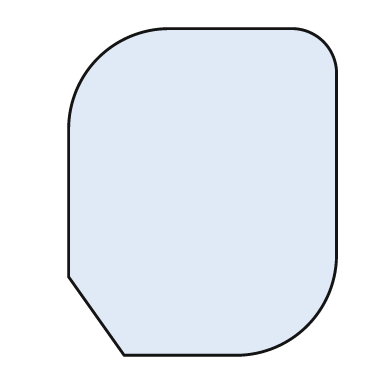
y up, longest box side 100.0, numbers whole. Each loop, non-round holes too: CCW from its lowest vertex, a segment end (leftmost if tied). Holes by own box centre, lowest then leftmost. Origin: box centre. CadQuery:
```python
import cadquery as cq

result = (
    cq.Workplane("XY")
    .moveTo(-24.0, -50.0)
    .lineTo(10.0, -50.0)
    .threePointArc((32.0, -41.0), (41.0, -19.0))
    .lineTo(41.0, 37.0)
    .threePointArc((37.0, 46.0), (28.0, 50.0))
    .lineTo(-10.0, 50.0)
    .threePointArc((-32.0, 41.0), (-41.0, 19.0))
    .lineTo(-41.0, -26.0)
    .close()
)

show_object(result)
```